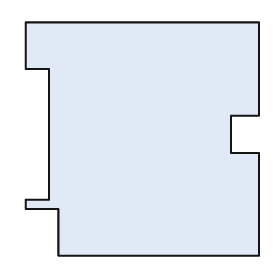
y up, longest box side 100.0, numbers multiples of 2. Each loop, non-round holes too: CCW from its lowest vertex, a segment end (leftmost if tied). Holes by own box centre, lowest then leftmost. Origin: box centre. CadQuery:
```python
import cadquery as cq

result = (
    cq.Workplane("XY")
    .moveTo(-36.0, -50.0)
    .lineTo(50.0, -50.0)
    .lineTo(50.0, -6.0)
    .lineTo(38.0, -6.0)
    .lineTo(38.0, 10.0)
    .lineTo(50.0, 10.0)
    .lineTo(50.0, 50.0)
    .lineTo(-50.0, 50.0)
    .lineTo(-50.0, 30.0)
    .lineTo(-40.0, 30.0)
    .lineTo(-40.0, -26.0)
    .lineTo(-50.0, -26.0)
    .lineTo(-50.0, -30.0)
    .lineTo(-36.0, -30.0)
    .close()
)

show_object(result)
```